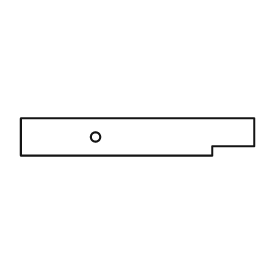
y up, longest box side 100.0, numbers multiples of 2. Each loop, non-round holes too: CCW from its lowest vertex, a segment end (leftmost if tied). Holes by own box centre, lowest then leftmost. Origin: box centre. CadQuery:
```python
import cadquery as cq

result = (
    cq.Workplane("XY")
    .moveTo(-50.0, -8.0)
    .lineTo(32.0, -8.0)
    .lineTo(32.0, -4.0)
    .lineTo(50.0, -4.0)
    .lineTo(50.0, 8.0)
    .lineTo(-50.0, 8.0)
    .close()
    .moveTo(-18.0, 0.0)
    .circle(2.0)
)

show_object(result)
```